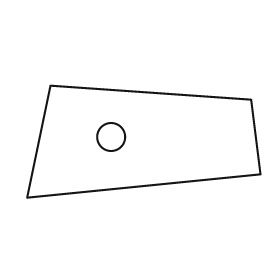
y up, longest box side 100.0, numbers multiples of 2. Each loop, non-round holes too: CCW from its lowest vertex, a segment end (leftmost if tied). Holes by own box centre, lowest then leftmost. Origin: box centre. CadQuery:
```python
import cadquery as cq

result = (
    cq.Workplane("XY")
    .moveTo(-50.0, -24.0)
    .lineTo(50.0, -14.0)
    .lineTo(46.0, 18.0)
    .lineTo(-40.0, 24.0)
    .close()
    .moveTo(-14.0, 2.0)
    .circle(6.0)
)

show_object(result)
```